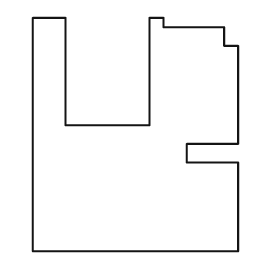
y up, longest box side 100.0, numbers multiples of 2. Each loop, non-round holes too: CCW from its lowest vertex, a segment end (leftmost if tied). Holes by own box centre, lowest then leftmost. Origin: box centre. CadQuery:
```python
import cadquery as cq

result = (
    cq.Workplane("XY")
    .moveTo(-44.0, -50.0)
    .lineTo(44.0, -50.0)
    .lineTo(44.0, -12.0)
    .lineTo(22.0, -12.0)
    .lineTo(22.0, -4.0)
    .lineTo(44.0, -4.0)
    .lineTo(44.0, 38.0)
    .lineTo(38.0, 38.0)
    .lineTo(38.0, 46.0)
    .lineTo(12.0, 46.0)
    .lineTo(12.0, 50.0)
    .lineTo(6.0, 50.0)
    .lineTo(6.0, 4.0)
    .lineTo(-30.0, 4.0)
    .lineTo(-30.0, 50.0)
    .lineTo(-44.0, 50.0)
    .close()
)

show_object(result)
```